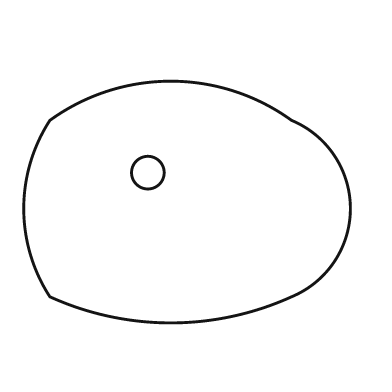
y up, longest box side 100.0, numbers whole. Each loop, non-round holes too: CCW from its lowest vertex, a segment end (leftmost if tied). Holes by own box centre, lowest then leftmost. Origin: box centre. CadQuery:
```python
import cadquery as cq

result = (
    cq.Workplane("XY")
    .moveTo(-42.0, -29.0)
    .threePointArc((-5.0, -37.0), (32.0, -29.0))
    .threePointArc((50.0, -2.0), (32.0, 25.0))
    .threePointArc((-5.0, 37.0), (-42.0, 25.0))
    .threePointArc((-50.0, -2.0), (-42.0, -29.0))
    .close()
    .moveTo(-12.0, 9.0)
    .circle(5.0)
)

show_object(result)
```